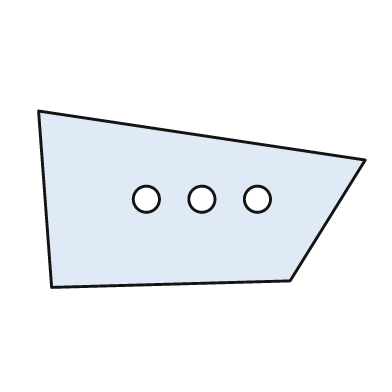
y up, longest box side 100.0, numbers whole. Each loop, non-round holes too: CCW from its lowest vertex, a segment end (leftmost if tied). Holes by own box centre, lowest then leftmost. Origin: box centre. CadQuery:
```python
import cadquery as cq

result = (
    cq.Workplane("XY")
    .moveTo(-46.0, -27.0)
    .lineTo(27.0, -25.0)
    .lineTo(50.0, 12.0)
    .lineTo(-50.0, 27.0)
    .close()
    .moveTo(-17.0, 0.0)
    .circle(4.0)
    .moveTo(0.0, 0.0)
    .circle(4.0)
    .moveTo(17.0, 0.0)
    .circle(4.0)
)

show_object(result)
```